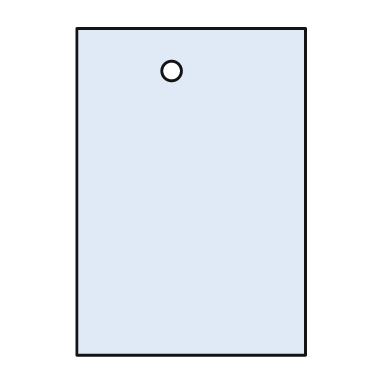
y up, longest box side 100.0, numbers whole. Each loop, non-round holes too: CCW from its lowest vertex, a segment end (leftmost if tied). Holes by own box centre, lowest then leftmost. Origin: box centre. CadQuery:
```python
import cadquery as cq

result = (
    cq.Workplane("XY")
    .moveTo(-35.0, -50.0)
    .lineTo(35.0, -50.0)
    .lineTo(35.0, 50.0)
    .lineTo(-35.0, 50.0)
    .close()
    .moveTo(-6.0, 37.0)
    .circle(3.0)
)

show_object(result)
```